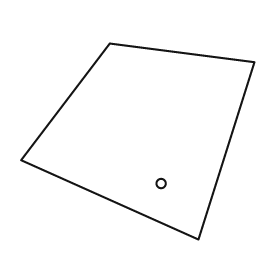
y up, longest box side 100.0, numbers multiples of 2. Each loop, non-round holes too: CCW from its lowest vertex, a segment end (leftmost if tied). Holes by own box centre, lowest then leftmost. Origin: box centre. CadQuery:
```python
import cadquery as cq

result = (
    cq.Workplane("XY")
    .moveTo(26.0, -42.0)
    .lineTo(50.0, 34.0)
    .lineTo(-12.0, 42.0)
    .lineTo(-50.0, -8.0)
    .close()
    .moveTo(10.0, -18.0)
    .circle(2.0)
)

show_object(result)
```